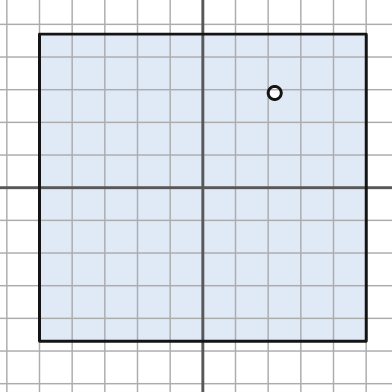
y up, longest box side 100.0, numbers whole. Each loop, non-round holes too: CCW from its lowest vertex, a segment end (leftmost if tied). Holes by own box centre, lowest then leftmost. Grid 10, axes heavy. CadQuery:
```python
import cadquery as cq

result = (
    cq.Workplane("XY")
    .moveTo(-50.0, -47.0)
    .lineTo(50.0, -47.0)
    .lineTo(50.0, 47.0)
    .lineTo(-50.0, 47.0)
    .close()
    .moveTo(22.0, 29.0)
    .circle(2.0)
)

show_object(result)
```